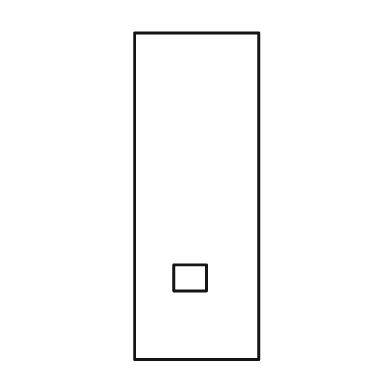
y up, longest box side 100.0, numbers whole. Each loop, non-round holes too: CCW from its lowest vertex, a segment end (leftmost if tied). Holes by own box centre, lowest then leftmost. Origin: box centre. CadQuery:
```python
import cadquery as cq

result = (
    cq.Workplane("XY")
    .moveTo(-19.0, -50.0)
    .lineTo(19.0, -50.0)
    .lineTo(19.0, 50.0)
    .lineTo(-19.0, 50.0)
    .close()
    .moveTo(-7.0, -29.0)
    .lineTo(3.0, -29.0)
    .lineTo(3.0, -21.0)
    .lineTo(-7.0, -21.0)
    .close()
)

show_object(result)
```